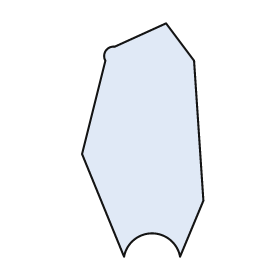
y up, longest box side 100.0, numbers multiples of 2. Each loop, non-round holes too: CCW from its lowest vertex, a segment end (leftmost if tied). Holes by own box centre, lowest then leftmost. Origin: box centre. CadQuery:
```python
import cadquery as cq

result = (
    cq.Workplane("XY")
    .moveTo(-8.0, -50.0)
    .threePointArc((4.0, -40.0), (16.0, -50.0))
    .lineTo(26.0, -26.0)
    .lineTo(22.0, 34.0)
    .lineTo(10.0, 50.0)
    .lineTo(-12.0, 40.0)
    .threePointArc((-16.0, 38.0), (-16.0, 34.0))
    .lineTo(-26.0, -6.0)
    .close()
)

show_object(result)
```